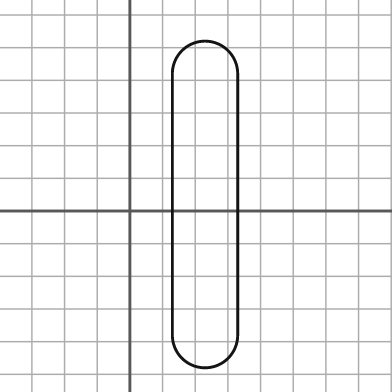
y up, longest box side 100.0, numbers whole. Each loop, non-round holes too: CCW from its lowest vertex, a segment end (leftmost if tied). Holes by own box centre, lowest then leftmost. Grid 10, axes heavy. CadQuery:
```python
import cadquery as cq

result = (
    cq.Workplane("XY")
    .moveTo(13.0, -38.0)
    .threePointArc((23.0, -48.0), (33.0, -38.0))
    .lineTo(33.0, 42.0)
    .threePointArc((23.0, 52.0), (13.0, 42.0))
    .close()
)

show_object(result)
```